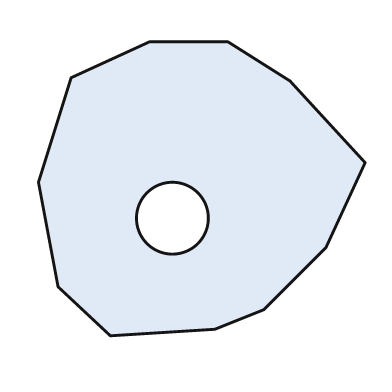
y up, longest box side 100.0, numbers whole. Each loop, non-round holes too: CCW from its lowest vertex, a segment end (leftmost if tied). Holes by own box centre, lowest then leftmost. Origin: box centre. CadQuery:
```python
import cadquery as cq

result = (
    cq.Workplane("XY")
    .moveTo(-28.0, -45.0)
    .lineTo(4.0, -43.0)
    .lineTo(19.0, -37.0)
    .lineTo(38.0, -18.0)
    .lineTo(50.0, 8.0)
    .lineTo(27.0, 33.0)
    .lineTo(8.0, 45.0)
    .lineTo(-16.0, 45.0)
    .lineTo(-40.0, 34.0)
    .lineTo(-50.0, 2.0)
    .lineTo(-44.0, -30.0)
    .close()
    .moveTo(-9.0, -9.0)
    .circle(11.0)
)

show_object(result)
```